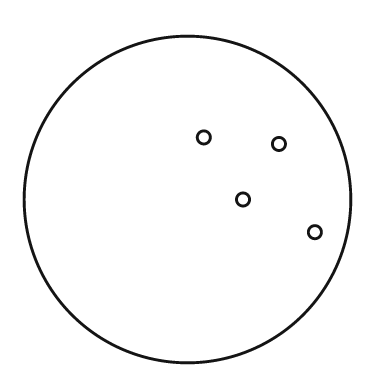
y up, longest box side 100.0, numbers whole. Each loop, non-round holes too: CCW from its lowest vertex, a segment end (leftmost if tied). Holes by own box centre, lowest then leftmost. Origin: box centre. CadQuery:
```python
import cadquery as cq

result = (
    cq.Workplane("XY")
    .moveTo(0.0, 0.0)
    .circle(50.0)
    .moveTo(39.0, -10.0)
    .circle(2.0)
    .moveTo(17.0, 0.0)
    .circle(2.0)
    .moveTo(28.0, 17.0)
    .circle(2.0)
    .moveTo(5.0, 19.0)
    .circle(2.0)
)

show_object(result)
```